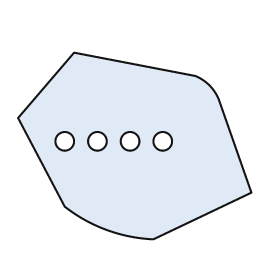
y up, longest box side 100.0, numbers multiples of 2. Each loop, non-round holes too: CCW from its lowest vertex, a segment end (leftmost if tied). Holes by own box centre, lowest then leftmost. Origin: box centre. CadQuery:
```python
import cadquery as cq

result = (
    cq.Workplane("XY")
    .moveTo(8.0, -40.0)
    .lineTo(50.0, -20.0)
    .lineTo(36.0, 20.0)
    .threePointArc((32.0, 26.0), (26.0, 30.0))
    .lineTo(-26.0, 40.0)
    .lineTo(-50.0, 12.0)
    .lineTo(-30.0, -26.0)
    .threePointArc((-12.0, -36.0), (8.0, -40.0))
    .close()
    .moveTo(-30.0, 2.0)
    .circle(4.0)
    .moveTo(-16.0, 2.0)
    .circle(4.0)
    .moveTo(-2.0, 2.0)
    .circle(4.0)
    .moveTo(12.0, 2.0)
    .circle(4.0)
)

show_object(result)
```